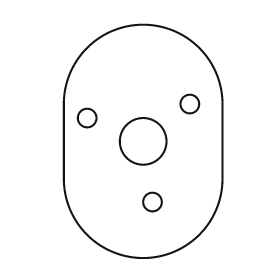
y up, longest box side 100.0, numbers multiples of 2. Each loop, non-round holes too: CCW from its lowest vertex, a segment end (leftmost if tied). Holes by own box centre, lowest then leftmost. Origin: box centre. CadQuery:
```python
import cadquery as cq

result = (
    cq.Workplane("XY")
    .moveTo(-34.0, -16.0)
    .threePointArc((0.0, -50.0), (34.0, -16.0))
    .lineTo(34.0, 16.0)
    .threePointArc((0.0, 50.0), (-34.0, 16.0))
    .close()
    .moveTo(4.0, -26.0)
    .circle(4.0)
    .moveTo(0.0, 0.0)
    .circle(10.0)
    .moveTo(-24.0, 10.0)
    .circle(4.0)
    .moveTo(20.0, 16.0)
    .circle(4.0)
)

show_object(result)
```